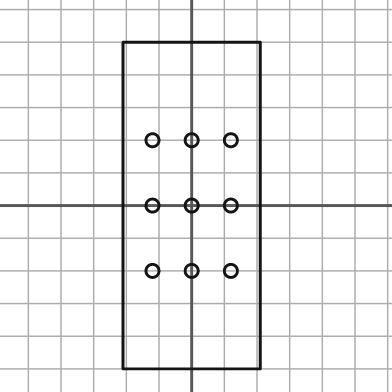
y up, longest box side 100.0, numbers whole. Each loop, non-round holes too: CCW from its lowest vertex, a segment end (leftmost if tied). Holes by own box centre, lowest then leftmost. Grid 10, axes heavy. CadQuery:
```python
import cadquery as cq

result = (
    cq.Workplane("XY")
    .moveTo(-21.0, -50.0)
    .lineTo(21.0, -50.0)
    .lineTo(21.0, 50.0)
    .lineTo(-21.0, 50.0)
    .close()
    .moveTo(-12.0, -20.0)
    .circle(2.0)
    .moveTo(0.0, -20.0)
    .circle(2.0)
    .moveTo(12.0, -20.0)
    .circle(2.0)
    .moveTo(-12.0, 0.0)
    .circle(2.0)
    .moveTo(0.0, 0.0)
    .circle(2.0)
    .moveTo(12.0, 0.0)
    .circle(2.0)
    .moveTo(-12.0, 20.0)
    .circle(2.0)
    .moveTo(0.0, 20.0)
    .circle(2.0)
    .moveTo(12.0, 20.0)
    .circle(2.0)
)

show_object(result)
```